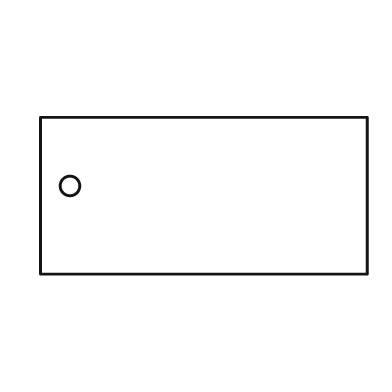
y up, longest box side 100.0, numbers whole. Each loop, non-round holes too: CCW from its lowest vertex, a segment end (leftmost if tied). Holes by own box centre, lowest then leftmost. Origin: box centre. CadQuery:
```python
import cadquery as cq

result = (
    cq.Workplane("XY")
    .moveTo(-50.0, -24.0)
    .lineTo(50.0, -24.0)
    .lineTo(50.0, 24.0)
    .lineTo(-50.0, 24.0)
    .close()
    .moveTo(-41.0, 3.0)
    .circle(3.0)
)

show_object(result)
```